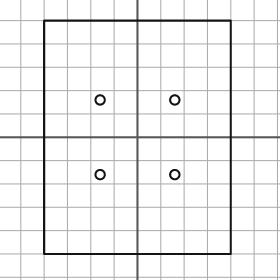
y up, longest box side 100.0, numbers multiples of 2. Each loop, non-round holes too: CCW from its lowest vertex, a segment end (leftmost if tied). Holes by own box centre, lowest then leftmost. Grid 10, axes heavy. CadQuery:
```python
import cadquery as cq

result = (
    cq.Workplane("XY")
    .moveTo(-40.0, -50.0)
    .lineTo(40.0, -50.0)
    .lineTo(40.0, 50.0)
    .lineTo(-40.0, 50.0)
    .close()
    .moveTo(-16.0, -16.0)
    .circle(2.0)
    .moveTo(16.0, -16.0)
    .circle(2.0)
    .moveTo(-16.0, 16.0)
    .circle(2.0)
    .moveTo(16.0, 16.0)
    .circle(2.0)
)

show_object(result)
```